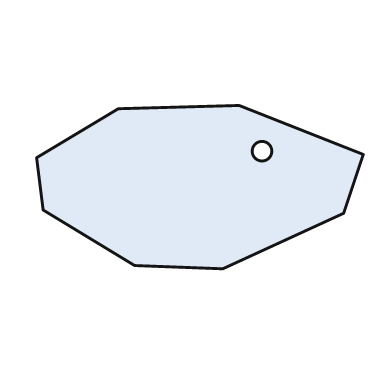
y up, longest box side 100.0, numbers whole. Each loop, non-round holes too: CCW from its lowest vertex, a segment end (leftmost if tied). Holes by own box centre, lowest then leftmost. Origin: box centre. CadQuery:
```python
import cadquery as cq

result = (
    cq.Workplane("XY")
    .moveTo(7.0, -25.0)
    .lineTo(44.0, -8.0)
    .lineTo(50.0, 10.0)
    .lineTo(12.0, 25.0)
    .lineTo(-25.0, 24.0)
    .lineTo(-50.0, 9.0)
    .lineTo(-48.0, -7.0)
    .lineTo(-20.0, -24.0)
    .close()
    .moveTo(19.0, 11.0)
    .circle(3.0)
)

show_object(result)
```